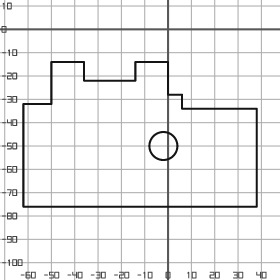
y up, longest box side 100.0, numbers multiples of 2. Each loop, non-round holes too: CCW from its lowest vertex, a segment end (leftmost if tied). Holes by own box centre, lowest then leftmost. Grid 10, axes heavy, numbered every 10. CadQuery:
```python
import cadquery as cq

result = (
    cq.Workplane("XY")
    .moveTo(-62.0, -76.0)
    .lineTo(38.0, -76.0)
    .lineTo(38.0, -34.0)
    .lineTo(6.0, -34.0)
    .lineTo(6.0, -28.0)
    .lineTo(0.0, -28.0)
    .lineTo(0.0, -14.0)
    .lineTo(-14.0, -14.0)
    .lineTo(-14.0, -22.0)
    .lineTo(-36.0, -22.0)
    .lineTo(-36.0, -14.0)
    .lineTo(-50.0, -14.0)
    .lineTo(-50.0, -32.0)
    .lineTo(-62.0, -32.0)
    .close()
    .moveTo(-2.0, -50.0)
    .circle(6.0)
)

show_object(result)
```